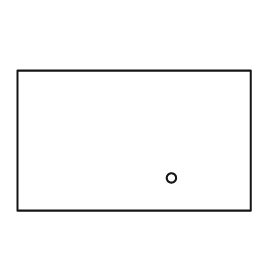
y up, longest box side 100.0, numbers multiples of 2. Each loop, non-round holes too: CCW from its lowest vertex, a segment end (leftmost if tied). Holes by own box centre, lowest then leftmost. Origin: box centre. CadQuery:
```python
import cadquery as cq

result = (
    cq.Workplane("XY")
    .moveTo(-50.0, -30.0)
    .lineTo(50.0, -30.0)
    .lineTo(50.0, 30.0)
    .lineTo(-50.0, 30.0)
    .close()
    .moveTo(16.0, -16.0)
    .circle(2.0)
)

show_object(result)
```